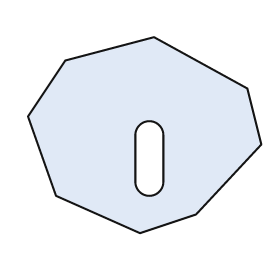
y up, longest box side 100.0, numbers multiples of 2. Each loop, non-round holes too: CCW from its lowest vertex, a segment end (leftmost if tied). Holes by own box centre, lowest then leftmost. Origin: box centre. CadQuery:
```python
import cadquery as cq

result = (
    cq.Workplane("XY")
    .moveTo(-2.0, -42.0)
    .lineTo(22.0, -34.0)
    .lineTo(50.0, -4.0)
    .lineTo(44.0, 20.0)
    .lineTo(4.0, 42.0)
    .lineTo(-34.0, 32.0)
    .lineTo(-50.0, 8.0)
    .lineTo(-38.0, -26.0)
    .close()
    .moveTo(-4.0, -20.0)
    .threePointArc((2.0, -26.0), (8.0, -20.0))
    .lineTo(8.0, 0.0)
    .threePointArc((2.0, 6.0), (-4.0, 0.0))
    .close()
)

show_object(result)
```